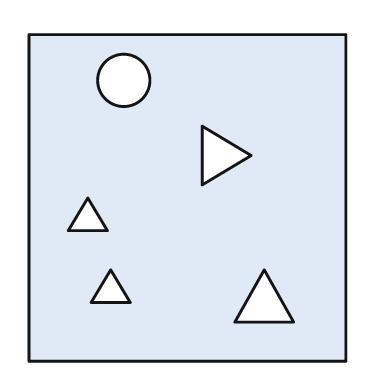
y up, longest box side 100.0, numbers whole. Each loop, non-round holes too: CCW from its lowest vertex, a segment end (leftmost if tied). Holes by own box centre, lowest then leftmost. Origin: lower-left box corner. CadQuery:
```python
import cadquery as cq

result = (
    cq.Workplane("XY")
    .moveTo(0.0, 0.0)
    .lineTo(97.0, 0.0)
    .lineTo(97.0, 100.0)
    .lineTo(0.0, 100.0)
    .close()
    .moveTo(63.0, 12.0)
    .lineTo(81.0, 12.0)
    .lineTo(72.0, 28.0)
    .close()
    .moveTo(19.0, 18.0)
    .lineTo(31.0, 18.0)
    .lineTo(25.0, 28.0)
    .close()
    .moveTo(12.0, 40.0)
    .lineTo(24.0, 40.0)
    .lineTo(18.0, 50.0)
    .close()
    .moveTo(53.0, 54.0)
    .lineTo(68.0, 63.0)
    .lineTo(53.0, 72.0)
    .close()
    .moveTo(29.0, 86.0)
    .circle(8.0)
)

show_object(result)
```